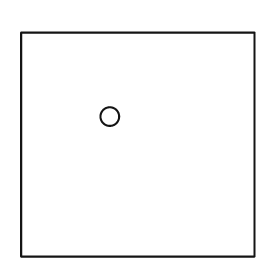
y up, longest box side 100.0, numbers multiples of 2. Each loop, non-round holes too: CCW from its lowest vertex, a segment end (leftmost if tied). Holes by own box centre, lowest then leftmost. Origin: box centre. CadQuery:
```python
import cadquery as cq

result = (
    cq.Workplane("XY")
    .moveTo(-50.0, -48.0)
    .lineTo(50.0, -48.0)
    .lineTo(50.0, 48.0)
    .lineTo(-50.0, 48.0)
    .close()
    .moveTo(-12.0, 12.0)
    .circle(4.0)
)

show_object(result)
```